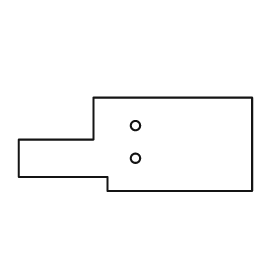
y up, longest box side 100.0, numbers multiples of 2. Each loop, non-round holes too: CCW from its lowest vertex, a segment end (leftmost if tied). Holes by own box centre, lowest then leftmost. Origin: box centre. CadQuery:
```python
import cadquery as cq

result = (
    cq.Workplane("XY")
    .moveTo(-12.0, -20.0)
    .lineTo(50.0, -20.0)
    .lineTo(50.0, 20.0)
    .lineTo(-18.0, 20.0)
    .lineTo(-18.0, 2.0)
    .lineTo(-50.0, 2.0)
    .lineTo(-50.0, -14.0)
    .lineTo(-12.0, -14.0)
    .close()
    .moveTo(0.0, -6.0)
    .circle(2.0)
    .moveTo(0.0, 8.0)
    .circle(2.0)
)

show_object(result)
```